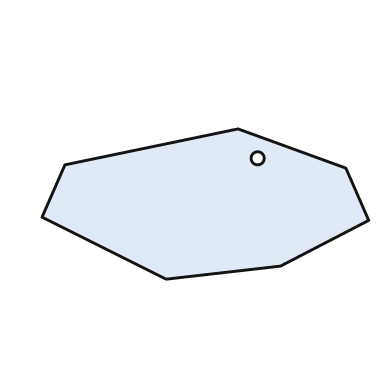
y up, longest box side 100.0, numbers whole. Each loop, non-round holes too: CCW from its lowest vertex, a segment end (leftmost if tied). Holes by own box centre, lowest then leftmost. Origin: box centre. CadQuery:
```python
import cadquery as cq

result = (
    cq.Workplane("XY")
    .moveTo(-12.0, -23.0)
    .lineTo(23.0, -19.0)
    .lineTo(50.0, -5.0)
    .lineTo(43.0, 11.0)
    .lineTo(10.0, 23.0)
    .lineTo(-43.0, 12.0)
    .lineTo(-50.0, -4.0)
    .close()
    .moveTo(16.0, 14.0)
    .circle(2.0)
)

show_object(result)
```